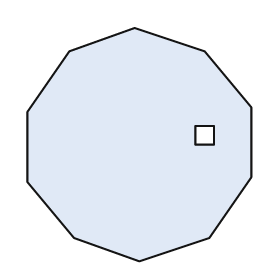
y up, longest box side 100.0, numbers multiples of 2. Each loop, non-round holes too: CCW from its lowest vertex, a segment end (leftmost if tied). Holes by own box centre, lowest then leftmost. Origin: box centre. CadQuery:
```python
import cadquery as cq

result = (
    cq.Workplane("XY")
    .moveTo(0.0, -50.0)
    .lineTo(30.0, -40.0)
    .lineTo(48.0, -14.0)
    .lineTo(48.0, 16.0)
    .lineTo(28.0, 40.0)
    .lineTo(-2.0, 50.0)
    .lineTo(-30.0, 40.0)
    .lineTo(-48.0, 14.0)
    .lineTo(-48.0, -16.0)
    .lineTo(-28.0, -40.0)
    .close()
    .moveTo(24.0, 0.0)
    .lineTo(32.0, 0.0)
    .lineTo(32.0, 8.0)
    .lineTo(24.0, 8.0)
    .close()
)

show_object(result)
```